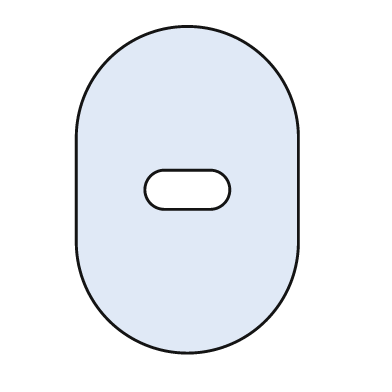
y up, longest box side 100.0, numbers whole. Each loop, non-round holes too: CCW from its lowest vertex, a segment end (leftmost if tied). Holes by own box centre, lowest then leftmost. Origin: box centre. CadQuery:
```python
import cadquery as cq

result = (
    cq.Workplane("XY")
    .moveTo(-34.0, -16.0)
    .threePointArc((0.0, -50.0), (34.0, -16.0))
    .lineTo(34.0, 16.0)
    .threePointArc((0.0, 50.0), (-34.0, 16.0))
    .close()
    .moveTo(-7.0, -6.0)
    .lineTo(7.0, -6.0)
    .threePointArc((13.0, 0.0), (7.0, 6.0))
    .lineTo(-7.0, 6.0)
    .threePointArc((-13.0, 0.0), (-7.0, -6.0))
    .close()
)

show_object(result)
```